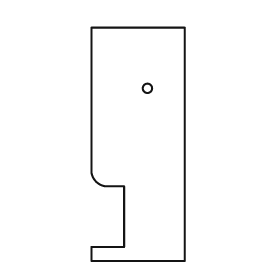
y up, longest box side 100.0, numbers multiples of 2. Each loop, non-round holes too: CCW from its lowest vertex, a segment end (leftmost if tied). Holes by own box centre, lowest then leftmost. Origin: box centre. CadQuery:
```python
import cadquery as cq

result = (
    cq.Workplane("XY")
    .moveTo(-20.0, -50.0)
    .lineTo(20.0, -50.0)
    .lineTo(20.0, 50.0)
    .lineTo(-20.0, 50.0)
    .lineTo(-20.0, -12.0)
    .threePointArc((-18.0, -16.0), (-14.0, -18.0))
    .lineTo(-6.0, -18.0)
    .lineTo(-6.0, -44.0)
    .lineTo(-20.0, -44.0)
    .close()
    .moveTo(4.0, 24.0)
    .circle(2.0)
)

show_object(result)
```